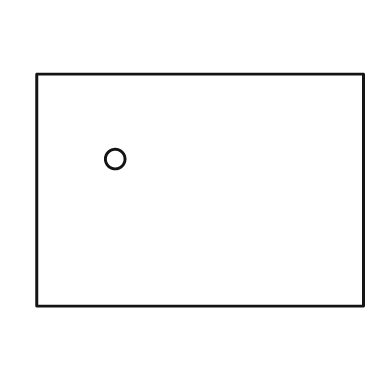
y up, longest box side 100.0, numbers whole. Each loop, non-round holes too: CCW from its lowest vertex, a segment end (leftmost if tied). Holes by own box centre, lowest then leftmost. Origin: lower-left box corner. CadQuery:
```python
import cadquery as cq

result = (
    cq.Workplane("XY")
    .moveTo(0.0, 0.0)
    .lineTo(100.0, 0.0)
    .lineTo(100.0, 71.0)
    .lineTo(0.0, 71.0)
    .close()
    .moveTo(24.0, 45.0)
    .circle(3.0)
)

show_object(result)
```